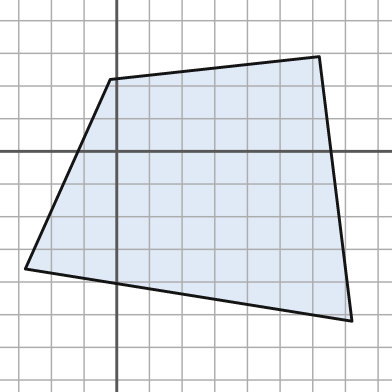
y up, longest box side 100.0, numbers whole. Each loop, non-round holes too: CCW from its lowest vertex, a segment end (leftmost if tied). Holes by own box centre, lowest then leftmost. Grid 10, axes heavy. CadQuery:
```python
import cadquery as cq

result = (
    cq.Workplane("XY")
    .moveTo(72.0, -52.0)
    .lineTo(62.0, 29.0)
    .lineTo(-2.0, 22.0)
    .lineTo(-28.0, -36.0)
    .close()
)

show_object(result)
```